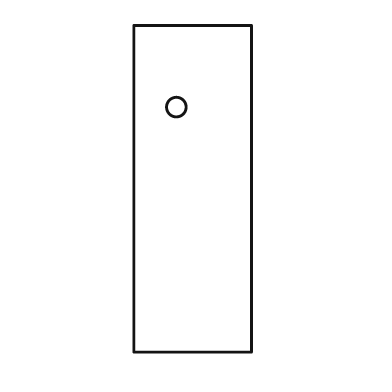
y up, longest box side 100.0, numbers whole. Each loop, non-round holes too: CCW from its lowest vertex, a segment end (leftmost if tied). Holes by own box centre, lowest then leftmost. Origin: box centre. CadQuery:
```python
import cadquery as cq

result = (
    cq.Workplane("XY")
    .moveTo(-18.0, -50.0)
    .lineTo(18.0, -50.0)
    .lineTo(18.0, 50.0)
    .lineTo(-18.0, 50.0)
    .close()
    .moveTo(-5.0, 25.0)
    .circle(3.0)
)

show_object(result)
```